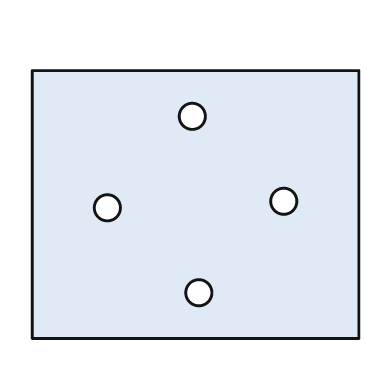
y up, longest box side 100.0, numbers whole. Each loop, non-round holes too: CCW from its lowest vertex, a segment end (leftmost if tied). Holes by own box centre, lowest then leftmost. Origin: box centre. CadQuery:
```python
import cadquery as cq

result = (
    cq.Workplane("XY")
    .moveTo(-50.0, -41.0)
    .lineTo(50.0, -41.0)
    .lineTo(50.0, 41.0)
    .lineTo(-50.0, 41.0)
    .close()
    .moveTo(1.0, -27.0)
    .circle(4.0)
    .moveTo(-27.0, -1.0)
    .circle(4.0)
    .moveTo(27.0, 1.0)
    .circle(4.0)
    .moveTo(-1.0, 27.0)
    .circle(4.0)
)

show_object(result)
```